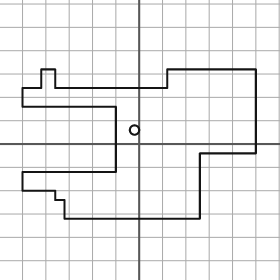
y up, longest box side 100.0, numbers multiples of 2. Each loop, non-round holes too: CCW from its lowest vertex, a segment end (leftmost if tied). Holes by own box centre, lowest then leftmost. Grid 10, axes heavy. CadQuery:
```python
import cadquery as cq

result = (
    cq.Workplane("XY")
    .moveTo(-32.0, -32.0)
    .lineTo(26.0, -32.0)
    .lineTo(26.0, -4.0)
    .lineTo(50.0, -4.0)
    .lineTo(50.0, 32.0)
    .lineTo(12.0, 32.0)
    .lineTo(12.0, 24.0)
    .lineTo(-36.0, 24.0)
    .lineTo(-36.0, 32.0)
    .lineTo(-42.0, 32.0)
    .lineTo(-42.0, 24.0)
    .lineTo(-50.0, 24.0)
    .lineTo(-50.0, 16.0)
    .lineTo(-10.0, 16.0)
    .lineTo(-10.0, -12.0)
    .lineTo(-50.0, -12.0)
    .lineTo(-50.0, -20.0)
    .lineTo(-36.0, -20.0)
    .lineTo(-36.0, -24.0)
    .lineTo(-32.0, -24.0)
    .close()
    .moveTo(-2.0, 6.0)
    .circle(2.0)
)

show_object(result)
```